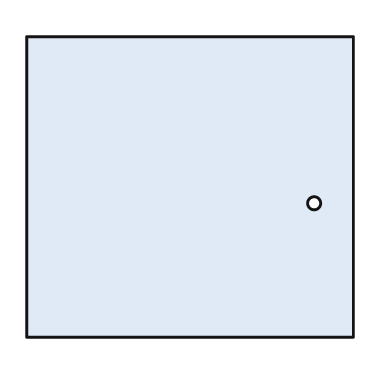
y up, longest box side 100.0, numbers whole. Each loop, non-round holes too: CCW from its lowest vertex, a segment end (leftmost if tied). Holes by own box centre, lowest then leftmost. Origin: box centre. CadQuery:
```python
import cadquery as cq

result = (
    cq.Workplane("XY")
    .moveTo(-50.0, -46.0)
    .lineTo(50.0, -46.0)
    .lineTo(50.0, 46.0)
    .lineTo(-50.0, 46.0)
    .close()
    .moveTo(38.0, -5.0)
    .circle(2.0)
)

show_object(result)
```